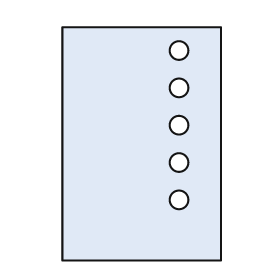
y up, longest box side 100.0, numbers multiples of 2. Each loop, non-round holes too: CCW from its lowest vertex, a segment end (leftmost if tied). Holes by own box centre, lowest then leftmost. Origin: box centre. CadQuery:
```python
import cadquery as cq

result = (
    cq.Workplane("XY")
    .moveTo(-34.0, -50.0)
    .lineTo(34.0, -50.0)
    .lineTo(34.0, 50.0)
    .lineTo(-34.0, 50.0)
    .close()
    .moveTo(16.0, -24.0)
    .circle(4.0)
    .moveTo(16.0, -8.0)
    .circle(4.0)
    .moveTo(16.0, 8.0)
    .circle(4.0)
    .moveTo(16.0, 24.0)
    .circle(4.0)
    .moveTo(16.0, 40.0)
    .circle(4.0)
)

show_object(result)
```